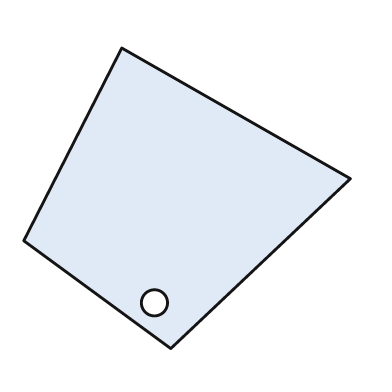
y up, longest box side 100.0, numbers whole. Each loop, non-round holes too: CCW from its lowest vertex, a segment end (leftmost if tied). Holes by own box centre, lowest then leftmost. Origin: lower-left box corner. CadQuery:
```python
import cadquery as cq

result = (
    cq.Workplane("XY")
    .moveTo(45.0, 0.0)
    .lineTo(100.0, 52.0)
    .lineTo(30.0, 92.0)
    .lineTo(0.0, 33.0)
    .close()
    .moveTo(40.0, 14.0)
    .circle(4.0)
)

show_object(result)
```